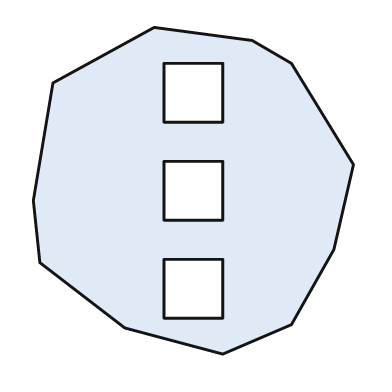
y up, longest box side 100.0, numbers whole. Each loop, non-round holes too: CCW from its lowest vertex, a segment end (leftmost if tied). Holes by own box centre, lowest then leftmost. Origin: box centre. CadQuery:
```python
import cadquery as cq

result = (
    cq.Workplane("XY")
    .moveTo(9.0, -50.0)
    .lineTo(30.0, -41.0)
    .lineTo(43.0, -18.0)
    .lineTo(49.0, 8.0)
    .lineTo(30.0, 39.0)
    .lineTo(18.0, 46.0)
    .lineTo(-12.0, 50.0)
    .lineTo(-43.0, 33.0)
    .lineTo(-49.0, -3.0)
    .lineTo(-47.0, -22.0)
    .lineTo(-21.0, -42.0)
    .close()
    .moveTo(-9.0, -39.0)
    .lineTo(9.0, -39.0)
    .lineTo(9.0, -21.0)
    .lineTo(-9.0, -21.0)
    .close()
    .moveTo(-9.0, -9.0)
    .lineTo(9.0, -9.0)
    .lineTo(9.0, 9.0)
    .lineTo(-9.0, 9.0)
    .close()
    .moveTo(-9.0, 21.0)
    .lineTo(9.0, 21.0)
    .lineTo(9.0, 39.0)
    .lineTo(-9.0, 39.0)
    .close()
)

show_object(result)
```